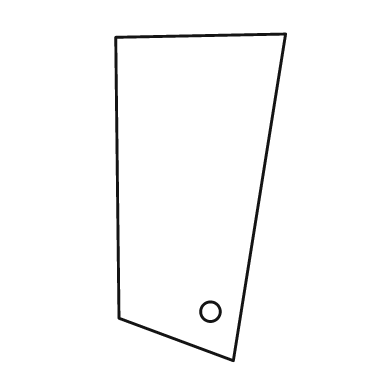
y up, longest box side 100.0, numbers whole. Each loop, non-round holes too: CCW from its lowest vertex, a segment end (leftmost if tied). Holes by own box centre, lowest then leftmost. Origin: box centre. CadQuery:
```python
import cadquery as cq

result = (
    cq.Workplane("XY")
    .moveTo(10.0, -50.0)
    .lineTo(26.0, 50.0)
    .lineTo(-26.0, 49.0)
    .lineTo(-25.0, -37.0)
    .close()
    .moveTo(3.0, -35.0)
    .circle(3.0)
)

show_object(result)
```